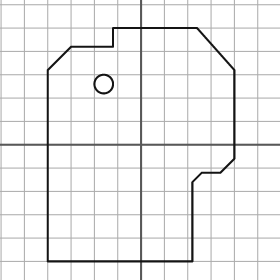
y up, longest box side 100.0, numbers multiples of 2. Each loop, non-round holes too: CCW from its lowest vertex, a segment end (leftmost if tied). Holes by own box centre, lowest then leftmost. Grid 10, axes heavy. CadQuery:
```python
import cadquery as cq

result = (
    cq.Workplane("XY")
    .moveTo(-40.0, -50.0)
    .lineTo(22.0, -50.0)
    .lineTo(22.0, -16.0)
    .lineTo(26.0, -12.0)
    .lineTo(34.0, -12.0)
    .lineTo(40.0, -6.0)
    .lineTo(40.0, 32.0)
    .lineTo(24.0, 50.0)
    .lineTo(-12.0, 50.0)
    .lineTo(-12.0, 42.0)
    .lineTo(-30.0, 42.0)
    .lineTo(-40.0, 32.0)
    .close()
    .moveTo(-16.0, 26.0)
    .circle(4.0)
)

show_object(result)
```